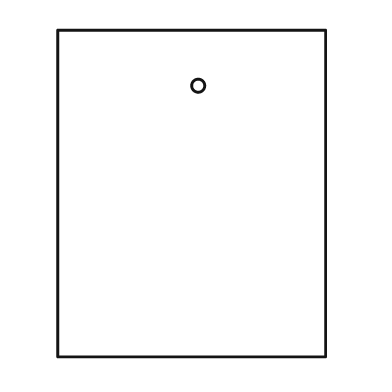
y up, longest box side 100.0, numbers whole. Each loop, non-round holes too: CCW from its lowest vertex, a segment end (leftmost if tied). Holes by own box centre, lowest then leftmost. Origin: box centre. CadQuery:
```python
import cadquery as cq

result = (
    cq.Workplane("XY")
    .moveTo(-41.0, -50.0)
    .lineTo(41.0, -50.0)
    .lineTo(41.0, 50.0)
    .lineTo(-41.0, 50.0)
    .close()
    .moveTo(2.0, 33.0)
    .circle(2.0)
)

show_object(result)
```